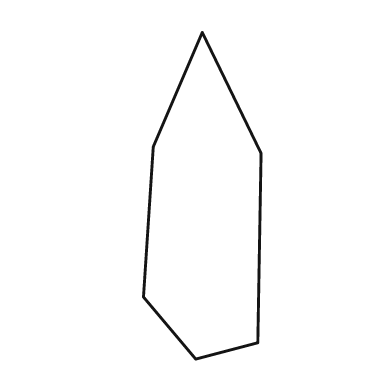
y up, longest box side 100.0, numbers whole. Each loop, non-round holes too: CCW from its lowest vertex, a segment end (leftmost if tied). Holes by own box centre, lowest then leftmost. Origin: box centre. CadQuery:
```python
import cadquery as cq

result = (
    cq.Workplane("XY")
    .moveTo(-2.0, -50.0)
    .lineTo(17.0, -45.0)
    .lineTo(18.0, 13.0)
    .lineTo(0.0, 50.0)
    .lineTo(-15.0, 15.0)
    .lineTo(-18.0, -31.0)
    .close()
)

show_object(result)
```